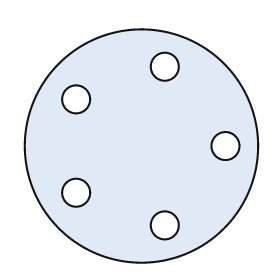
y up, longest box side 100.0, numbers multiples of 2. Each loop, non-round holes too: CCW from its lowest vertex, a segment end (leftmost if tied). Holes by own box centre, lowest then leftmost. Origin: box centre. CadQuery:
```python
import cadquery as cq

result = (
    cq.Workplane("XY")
    .moveTo(0.0, 0.0)
    .circle(50.0)
    .moveTo(10.0, -34.0)
    .circle(6.0)
    .moveTo(-28.0, -20.0)
    .circle(6.0)
    .moveTo(36.0, 0.0)
    .circle(6.0)
    .moveTo(-28.0, 20.0)
    .circle(6.0)
    .moveTo(10.0, 34.0)
    .circle(6.0)
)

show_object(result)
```